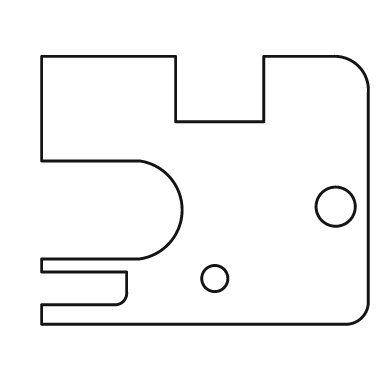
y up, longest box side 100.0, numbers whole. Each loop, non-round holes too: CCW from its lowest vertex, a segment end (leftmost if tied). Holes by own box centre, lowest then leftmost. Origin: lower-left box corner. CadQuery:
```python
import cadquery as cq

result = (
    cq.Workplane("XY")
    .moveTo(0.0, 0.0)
    .lineTo(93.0, 0.0)
    .threePointArc((98.0, 2.0), (100.0, 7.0))
    .lineTo(100.0, 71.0)
    .threePointArc((97.0, 79.0), (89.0, 82.0))
    .lineTo(68.0, 82.0)
    .lineTo(68.0, 62.0)
    .lineTo(41.0, 62.0)
    .lineTo(41.0, 82.0)
    .lineTo(0.0, 82.0)
    .lineTo(0.0, 50.0)
    .lineTo(30.0, 50.0)
    .threePointArc((43.0, 35.0), (30.0, 20.0))
    .lineTo(0.0, 20.0)
    .lineTo(0.0, 16.0)
    .lineTo(26.0, 16.0)
    .lineTo(26.0, 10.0)
    .threePointArc((25.0, 7.0), (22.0, 6.0))
    .lineTo(0.0, 6.0)
    .close()
    .moveTo(53.0, 14.0)
    .circle(4.0)
    .moveTo(90.0, 36.0)
    .circle(6.0)
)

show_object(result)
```